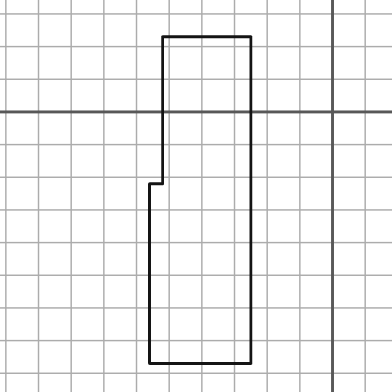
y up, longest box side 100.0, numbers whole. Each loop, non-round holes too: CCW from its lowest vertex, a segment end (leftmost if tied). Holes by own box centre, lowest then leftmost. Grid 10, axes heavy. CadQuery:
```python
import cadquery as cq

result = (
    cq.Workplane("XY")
    .moveTo(-56.0, -77.0)
    .lineTo(-25.0, -77.0)
    .lineTo(-25.0, 23.0)
    .lineTo(-52.0, 23.0)
    .lineTo(-52.0, -22.0)
    .lineTo(-56.0, -22.0)
    .close()
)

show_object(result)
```